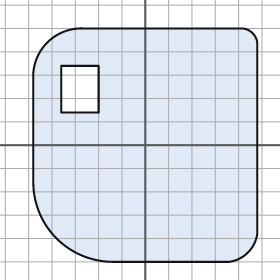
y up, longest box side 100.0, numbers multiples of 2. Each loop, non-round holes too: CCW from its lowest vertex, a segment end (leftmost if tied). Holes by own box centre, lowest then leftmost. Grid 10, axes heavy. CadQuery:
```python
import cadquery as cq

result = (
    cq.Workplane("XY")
    .moveTo(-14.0, -50.0)
    .lineTo(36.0, -50.0)
    .threePointArc((44.0, -46.0), (48.0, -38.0))
    .lineTo(48.0, 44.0)
    .threePointArc((46.0, 48.0), (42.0, 50.0))
    .lineTo(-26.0, 50.0)
    .threePointArc((-42.0, 44.0), (-48.0, 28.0))
    .lineTo(-48.0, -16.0)
    .threePointArc((-38.0, -40.0), (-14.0, -50.0))
    .close()
    .moveTo(-36.0, 14.0)
    .lineTo(-20.0, 14.0)
    .lineTo(-20.0, 34.0)
    .lineTo(-36.0, 34.0)
    .close()
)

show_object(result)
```